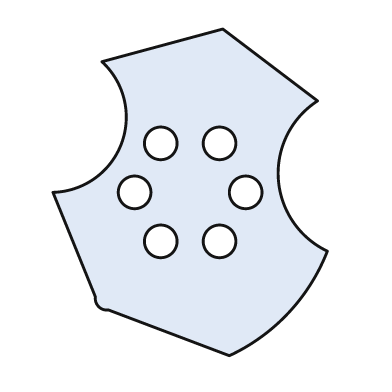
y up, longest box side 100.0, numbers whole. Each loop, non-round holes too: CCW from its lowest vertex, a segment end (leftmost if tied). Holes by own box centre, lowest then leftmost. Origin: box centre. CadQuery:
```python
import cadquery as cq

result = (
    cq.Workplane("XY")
    .moveTo(12.0, -50.0)
    .threePointArc((30.0, -37.0), (42.0, -18.0))
    .threePointArc((27.0, 4.0), (39.0, 28.0))
    .lineTo(10.0, 50.0)
    .lineTo(-27.0, 40.0)
    .threePointArc((-21.0, 15.0), (-42.0, 0.0))
    .lineTo(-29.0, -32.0)
    .threePointArc((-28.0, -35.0), (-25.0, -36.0))
    .close()
    .moveTo(-9.0, -15.0)
    .circle(5.0)
    .moveTo(9.0, -15.0)
    .circle(5.0)
    .moveTo(-17.0, 0.0)
    .circle(5.0)
    .moveTo(17.0, 0.0)
    .circle(5.0)
    .moveTo(-9.0, 15.0)
    .circle(5.0)
    .moveTo(9.0, 15.0)
    .circle(5.0)
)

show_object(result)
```